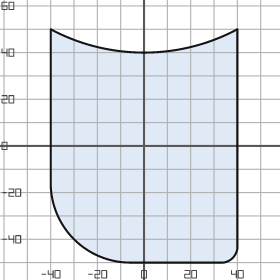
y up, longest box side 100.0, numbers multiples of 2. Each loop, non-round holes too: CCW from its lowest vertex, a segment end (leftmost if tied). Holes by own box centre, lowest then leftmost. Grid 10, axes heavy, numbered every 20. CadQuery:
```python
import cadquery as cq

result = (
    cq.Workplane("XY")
    .moveTo(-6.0, -50.0)
    .lineTo(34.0, -50.0)
    .threePointArc((38.0, -48.0), (40.0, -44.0))
    .lineTo(40.0, 50.0)
    .threePointArc((0.0, 40.0), (-40.0, 50.0))
    .lineTo(-40.0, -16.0)
    .threePointArc((-30.0, -40.0), (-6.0, -50.0))
    .close()
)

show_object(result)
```